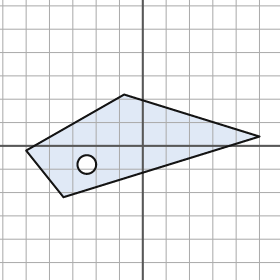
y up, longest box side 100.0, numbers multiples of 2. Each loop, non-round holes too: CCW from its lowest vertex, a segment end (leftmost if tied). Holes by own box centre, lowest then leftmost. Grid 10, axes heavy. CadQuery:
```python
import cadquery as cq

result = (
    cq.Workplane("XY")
    .moveTo(-34.0, -22.0)
    .lineTo(50.0, 4.0)
    .lineTo(-8.0, 22.0)
    .lineTo(-50.0, -2.0)
    .close()
    .moveTo(-24.0, -8.0)
    .circle(4.0)
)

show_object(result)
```